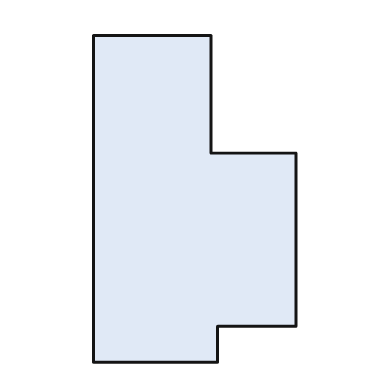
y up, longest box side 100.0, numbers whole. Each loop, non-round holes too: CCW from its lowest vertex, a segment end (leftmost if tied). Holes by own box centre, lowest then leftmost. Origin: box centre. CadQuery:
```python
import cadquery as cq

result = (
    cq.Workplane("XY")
    .moveTo(-31.0, -50.0)
    .lineTo(7.0, -50.0)
    .lineTo(7.0, -39.0)
    .lineTo(31.0, -39.0)
    .lineTo(31.0, 14.0)
    .lineTo(5.0, 14.0)
    .lineTo(5.0, 50.0)
    .lineTo(-31.0, 50.0)
    .close()
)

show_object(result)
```